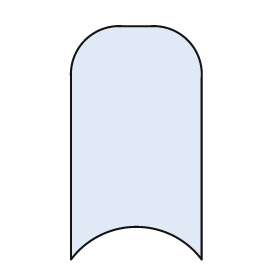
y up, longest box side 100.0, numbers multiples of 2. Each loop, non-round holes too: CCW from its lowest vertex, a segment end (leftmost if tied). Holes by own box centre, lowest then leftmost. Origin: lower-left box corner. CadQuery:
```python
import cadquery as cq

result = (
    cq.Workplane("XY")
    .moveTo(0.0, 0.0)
    .threePointArc((28.0, 14.0), (56.0, 0.0))
    .lineTo(56.0, 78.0)
    .threePointArc((50.0, 94.0), (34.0, 100.0))
    .lineTo(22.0, 100.0)
    .threePointArc((6.0, 94.0), (0.0, 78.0))
    .close()
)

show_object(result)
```